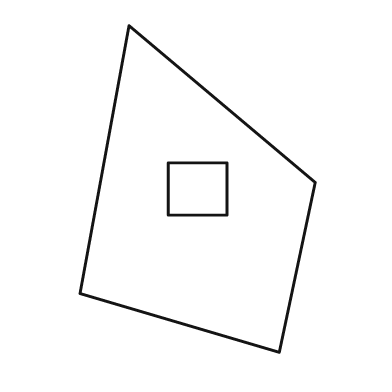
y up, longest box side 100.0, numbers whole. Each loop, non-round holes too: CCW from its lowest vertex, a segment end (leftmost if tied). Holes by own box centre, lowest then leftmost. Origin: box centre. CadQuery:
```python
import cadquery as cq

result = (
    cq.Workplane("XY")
    .moveTo(25.0, -50.0)
    .lineTo(36.0, 2.0)
    .lineTo(-21.0, 50.0)
    .lineTo(-36.0, -32.0)
    .close()
    .moveTo(-9.0, -8.0)
    .lineTo(9.0, -8.0)
    .lineTo(9.0, 8.0)
    .lineTo(-9.0, 8.0)
    .close()
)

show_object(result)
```